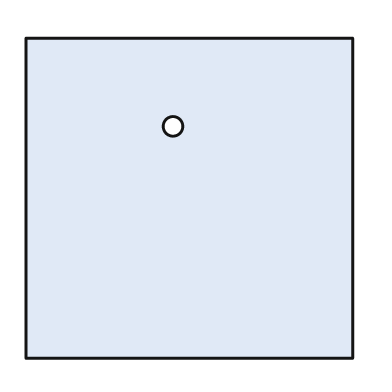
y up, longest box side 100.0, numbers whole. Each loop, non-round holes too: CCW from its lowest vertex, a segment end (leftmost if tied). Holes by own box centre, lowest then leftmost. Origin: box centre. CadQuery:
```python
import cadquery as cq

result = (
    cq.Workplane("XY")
    .moveTo(-50.0, -49.0)
    .lineTo(50.0, -49.0)
    .lineTo(50.0, 49.0)
    .lineTo(-50.0, 49.0)
    .close()
    .moveTo(-5.0, 22.0)
    .circle(3.0)
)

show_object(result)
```